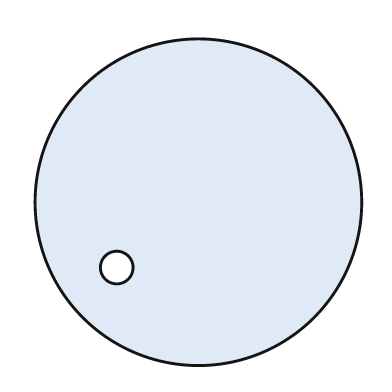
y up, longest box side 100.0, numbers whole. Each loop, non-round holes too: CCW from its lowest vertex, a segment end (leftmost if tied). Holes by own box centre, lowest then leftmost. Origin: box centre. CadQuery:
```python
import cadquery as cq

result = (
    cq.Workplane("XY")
    .moveTo(0.0, 0.0)
    .circle(50.0)
    .moveTo(-25.0, -20.0)
    .circle(5.0)
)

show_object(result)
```